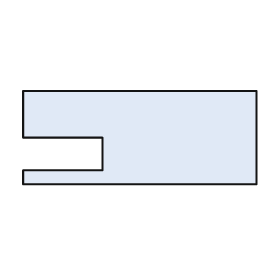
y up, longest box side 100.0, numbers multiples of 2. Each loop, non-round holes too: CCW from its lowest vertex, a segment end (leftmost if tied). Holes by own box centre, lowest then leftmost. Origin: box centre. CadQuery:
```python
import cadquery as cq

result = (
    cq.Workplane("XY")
    .moveTo(-50.0, -20.0)
    .lineTo(50.0, -20.0)
    .lineTo(50.0, 20.0)
    .lineTo(-50.0, 20.0)
    .lineTo(-50.0, 0.0)
    .lineTo(-16.0, 0.0)
    .lineTo(-16.0, -14.0)
    .lineTo(-50.0, -14.0)
    .close()
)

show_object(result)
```